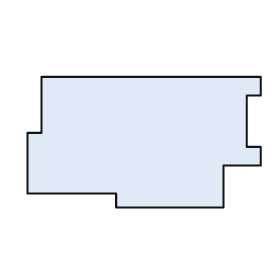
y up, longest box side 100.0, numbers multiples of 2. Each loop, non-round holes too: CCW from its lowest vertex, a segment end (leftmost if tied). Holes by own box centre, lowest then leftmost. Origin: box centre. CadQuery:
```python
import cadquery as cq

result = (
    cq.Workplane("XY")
    .moveTo(-12.0, -28.0)
    .lineTo(34.0, -28.0)
    .lineTo(34.0, -10.0)
    .lineTo(50.0, -10.0)
    .lineTo(50.0, -2.0)
    .lineTo(44.0, -2.0)
    .lineTo(44.0, 20.0)
    .lineTo(50.0, 20.0)
    .lineTo(50.0, 28.0)
    .lineTo(-44.0, 28.0)
    .lineTo(-44.0, 4.0)
    .lineTo(-50.0, 4.0)
    .lineTo(-50.0, -22.0)
    .lineTo(-12.0, -22.0)
    .close()
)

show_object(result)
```